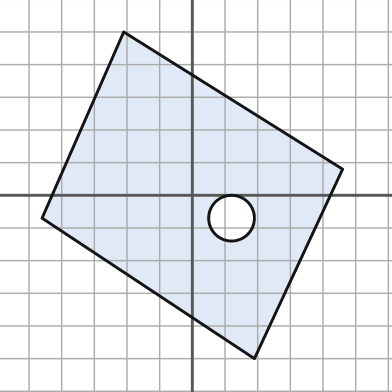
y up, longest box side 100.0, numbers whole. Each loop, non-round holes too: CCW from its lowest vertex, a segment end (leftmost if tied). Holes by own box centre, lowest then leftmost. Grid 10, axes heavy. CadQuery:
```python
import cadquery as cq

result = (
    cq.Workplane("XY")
    .moveTo(19.0, -50.0)
    .lineTo(46.0, 8.0)
    .lineTo(-21.0, 50.0)
    .lineTo(-46.0, -7.0)
    .close()
    .moveTo(12.0, -7.0)
    .circle(7.0)
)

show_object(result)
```